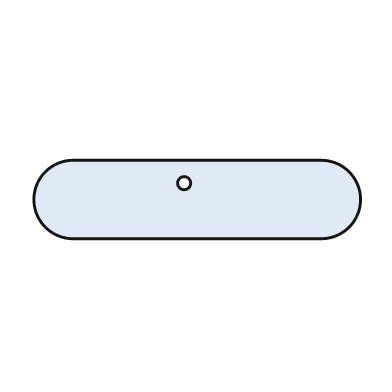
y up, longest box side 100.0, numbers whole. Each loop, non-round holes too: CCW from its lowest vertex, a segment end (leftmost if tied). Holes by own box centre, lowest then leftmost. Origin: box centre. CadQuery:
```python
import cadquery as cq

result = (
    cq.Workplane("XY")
    .moveTo(-38.0, -12.0)
    .lineTo(38.0, -12.0)
    .threePointArc((50.0, 0.0), (38.0, 12.0))
    .lineTo(-38.0, 12.0)
    .threePointArc((-50.0, 0.0), (-38.0, -12.0))
    .close()
    .moveTo(-4.0, 5.0)
    .circle(2.0)
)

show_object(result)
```